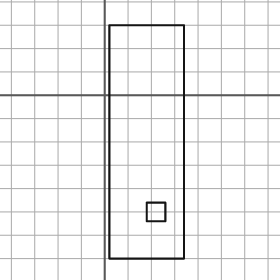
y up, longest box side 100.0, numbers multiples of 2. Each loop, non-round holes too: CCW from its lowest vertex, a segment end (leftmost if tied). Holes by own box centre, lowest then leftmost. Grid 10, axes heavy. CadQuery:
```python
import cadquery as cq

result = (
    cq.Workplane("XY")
    .moveTo(2.0, -70.0)
    .lineTo(34.0, -70.0)
    .lineTo(34.0, 30.0)
    .lineTo(2.0, 30.0)
    .close()
    .moveTo(18.0, -54.0)
    .lineTo(26.0, -54.0)
    .lineTo(26.0, -46.0)
    .lineTo(18.0, -46.0)
    .close()
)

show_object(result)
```